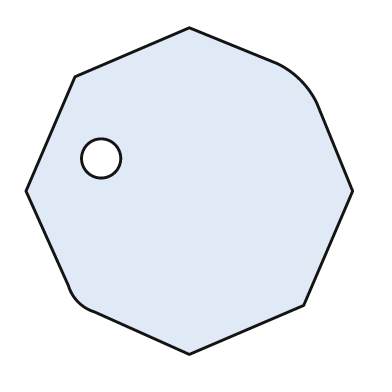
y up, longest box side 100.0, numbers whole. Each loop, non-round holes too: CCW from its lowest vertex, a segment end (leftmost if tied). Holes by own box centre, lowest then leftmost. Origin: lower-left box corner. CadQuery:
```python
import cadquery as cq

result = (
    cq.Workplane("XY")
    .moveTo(50.0, 0.0)
    .lineTo(85.0, 15.0)
    .lineTo(100.0, 50.0)
    .lineTo(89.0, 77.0)
    .threePointArc((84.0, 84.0), (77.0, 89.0))
    .lineTo(50.0, 100.0)
    .lineTo(15.0, 85.0)
    .lineTo(0.0, 50.0)
    .lineTo(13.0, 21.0)
    .threePointArc((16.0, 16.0), (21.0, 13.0))
    .close()
    .moveTo(23.0, 60.0)
    .circle(6.0)
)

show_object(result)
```